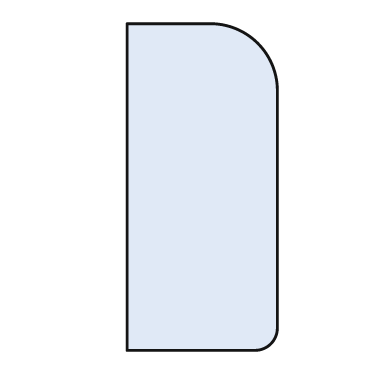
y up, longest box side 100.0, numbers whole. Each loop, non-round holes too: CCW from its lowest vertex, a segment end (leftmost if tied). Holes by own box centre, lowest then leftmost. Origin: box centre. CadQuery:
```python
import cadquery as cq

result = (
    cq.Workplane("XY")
    .moveTo(-23.0, -50.0)
    .lineTo(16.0, -50.0)
    .threePointArc((21.0, -48.0), (23.0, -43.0))
    .lineTo(23.0, 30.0)
    .threePointArc((17.0, 44.0), (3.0, 50.0))
    .lineTo(-23.0, 50.0)
    .close()
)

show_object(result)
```